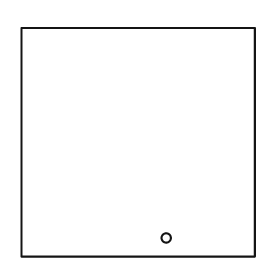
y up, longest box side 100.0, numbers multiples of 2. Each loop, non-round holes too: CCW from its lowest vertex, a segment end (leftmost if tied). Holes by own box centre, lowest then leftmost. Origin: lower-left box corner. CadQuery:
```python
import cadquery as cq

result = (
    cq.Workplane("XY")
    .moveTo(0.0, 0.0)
    .lineTo(100.0, 0.0)
    .lineTo(100.0, 98.0)
    .lineTo(0.0, 98.0)
    .close()
    .moveTo(62.0, 8.0)
    .circle(2.0)
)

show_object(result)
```